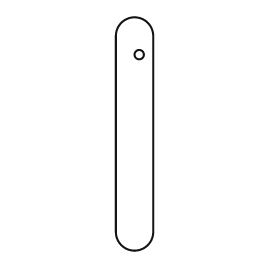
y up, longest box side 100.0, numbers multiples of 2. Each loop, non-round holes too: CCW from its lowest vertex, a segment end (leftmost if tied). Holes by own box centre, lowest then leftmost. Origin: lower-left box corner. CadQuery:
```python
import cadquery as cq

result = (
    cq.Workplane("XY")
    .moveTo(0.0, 8.0)
    .threePointArc((8.0, 0.0), (16.0, 8.0))
    .lineTo(16.0, 92.0)
    .threePointArc((8.0, 100.0), (0.0, 92.0))
    .close()
    .moveTo(10.0, 84.0)
    .circle(2.0)
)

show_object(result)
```